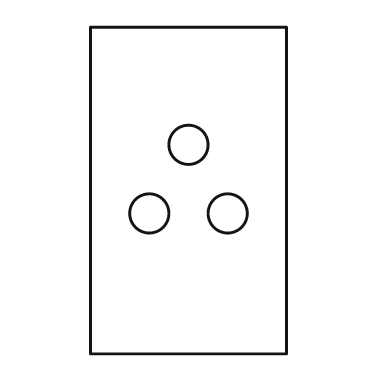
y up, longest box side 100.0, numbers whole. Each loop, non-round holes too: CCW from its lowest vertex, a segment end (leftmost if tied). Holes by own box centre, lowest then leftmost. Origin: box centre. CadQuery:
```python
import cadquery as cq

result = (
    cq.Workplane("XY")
    .moveTo(-30.0, -50.0)
    .lineTo(30.0, -50.0)
    .lineTo(30.0, 50.0)
    .lineTo(-30.0, 50.0)
    .close()
    .moveTo(-12.0, -7.0)
    .circle(6.0)
    .moveTo(12.0, -7.0)
    .circle(6.0)
    .moveTo(0.0, 14.0)
    .circle(6.0)
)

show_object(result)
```